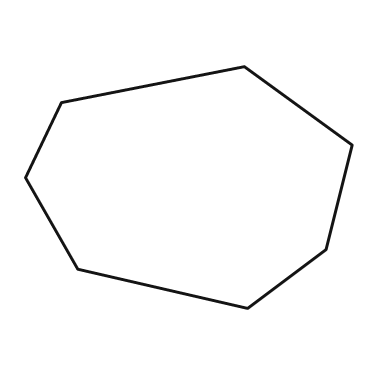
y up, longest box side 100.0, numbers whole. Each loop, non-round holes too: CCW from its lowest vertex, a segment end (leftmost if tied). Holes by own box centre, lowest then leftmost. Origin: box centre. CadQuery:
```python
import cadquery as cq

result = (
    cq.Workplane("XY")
    .moveTo(18.0, -37.0)
    .lineTo(42.0, -19.0)
    .lineTo(50.0, 13.0)
    .lineTo(17.0, 37.0)
    .lineTo(-39.0, 26.0)
    .lineTo(-50.0, 3.0)
    .lineTo(-34.0, -25.0)
    .close()
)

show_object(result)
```